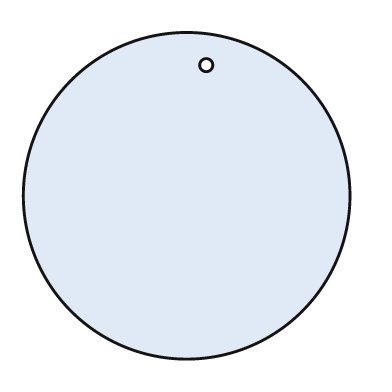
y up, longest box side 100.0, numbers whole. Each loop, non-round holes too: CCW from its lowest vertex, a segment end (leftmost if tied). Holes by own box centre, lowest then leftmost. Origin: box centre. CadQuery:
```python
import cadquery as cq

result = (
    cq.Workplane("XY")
    .moveTo(0.0, 0.0)
    .circle(50.0)
    .moveTo(6.0, 40.0)
    .circle(2.0)
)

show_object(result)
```